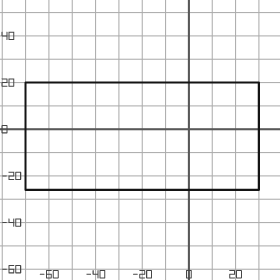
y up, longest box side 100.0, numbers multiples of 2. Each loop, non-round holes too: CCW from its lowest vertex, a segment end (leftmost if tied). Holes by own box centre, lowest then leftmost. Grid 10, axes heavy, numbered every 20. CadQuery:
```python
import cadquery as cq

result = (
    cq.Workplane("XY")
    .moveTo(-70.0, -26.0)
    .lineTo(30.0, -26.0)
    .lineTo(30.0, 20.0)
    .lineTo(-70.0, 20.0)
    .close()
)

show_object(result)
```